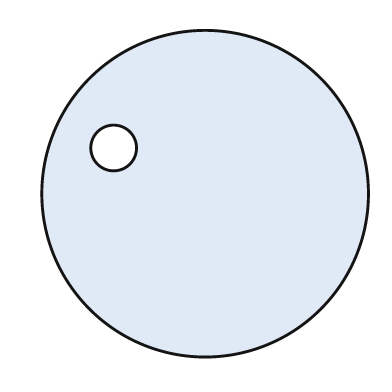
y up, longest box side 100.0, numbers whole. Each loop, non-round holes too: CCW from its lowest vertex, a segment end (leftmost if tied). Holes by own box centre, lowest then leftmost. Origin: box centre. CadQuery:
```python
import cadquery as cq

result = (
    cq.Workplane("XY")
    .moveTo(0.0, 0.0)
    .circle(50.0)
    .moveTo(-28.0, 14.0)
    .circle(7.0)
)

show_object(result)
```